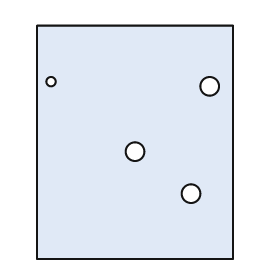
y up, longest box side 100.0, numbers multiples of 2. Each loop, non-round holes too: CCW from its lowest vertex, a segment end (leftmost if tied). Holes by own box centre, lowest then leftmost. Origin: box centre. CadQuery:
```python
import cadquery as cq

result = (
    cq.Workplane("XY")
    .moveTo(-42.0, -50.0)
    .lineTo(42.0, -50.0)
    .lineTo(42.0, 50.0)
    .lineTo(-42.0, 50.0)
    .close()
    .moveTo(24.0, -22.0)
    .circle(4.0)
    .moveTo(0.0, -4.0)
    .circle(4.0)
    .moveTo(32.0, 24.0)
    .circle(4.0)
    .moveTo(-36.0, 26.0)
    .circle(2.0)
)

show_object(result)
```